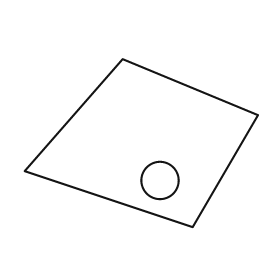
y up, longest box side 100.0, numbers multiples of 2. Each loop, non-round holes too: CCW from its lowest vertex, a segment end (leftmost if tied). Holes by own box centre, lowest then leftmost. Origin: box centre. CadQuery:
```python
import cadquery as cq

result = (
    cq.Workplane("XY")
    .moveTo(22.0, -36.0)
    .lineTo(50.0, 12.0)
    .lineTo(-8.0, 36.0)
    .lineTo(-50.0, -12.0)
    .close()
    .moveTo(8.0, -16.0)
    .circle(8.0)
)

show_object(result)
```